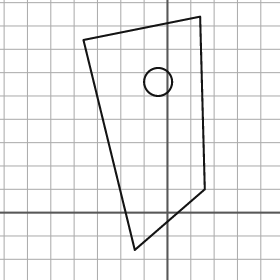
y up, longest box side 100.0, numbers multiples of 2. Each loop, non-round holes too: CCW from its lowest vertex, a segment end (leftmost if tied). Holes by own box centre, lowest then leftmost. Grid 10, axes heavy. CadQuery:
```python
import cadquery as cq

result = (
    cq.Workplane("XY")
    .moveTo(-14.0, -16.0)
    .lineTo(16.0, 10.0)
    .lineTo(14.0, 84.0)
    .lineTo(-36.0, 74.0)
    .close()
    .moveTo(-4.0, 56.0)
    .circle(6.0)
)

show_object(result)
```